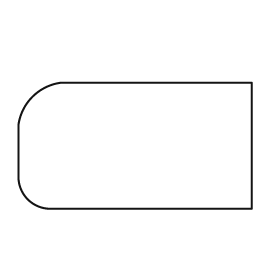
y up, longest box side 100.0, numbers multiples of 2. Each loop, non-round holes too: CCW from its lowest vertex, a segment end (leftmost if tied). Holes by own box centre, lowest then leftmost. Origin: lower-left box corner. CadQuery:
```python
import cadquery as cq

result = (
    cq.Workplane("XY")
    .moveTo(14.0, 0.0)
    .lineTo(100.0, 0.0)
    .lineTo(100.0, 54.0)
    .lineTo(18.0, 54.0)
    .threePointArc((6.0, 48.0), (0.0, 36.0))
    .lineTo(0.0, 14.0)
    .threePointArc((4.0, 4.0), (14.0, 0.0))
    .close()
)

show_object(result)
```